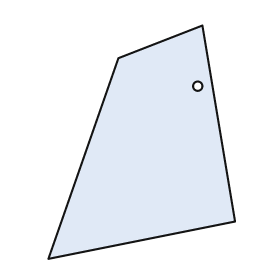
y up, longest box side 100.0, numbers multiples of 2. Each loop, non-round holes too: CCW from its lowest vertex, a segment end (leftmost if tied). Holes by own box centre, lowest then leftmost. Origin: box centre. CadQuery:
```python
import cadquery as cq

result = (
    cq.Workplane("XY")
    .moveTo(-40.0, -50.0)
    .lineTo(40.0, -34.0)
    .lineTo(26.0, 50.0)
    .lineTo(-10.0, 36.0)
    .close()
    .moveTo(24.0, 24.0)
    .circle(2.0)
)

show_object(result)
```